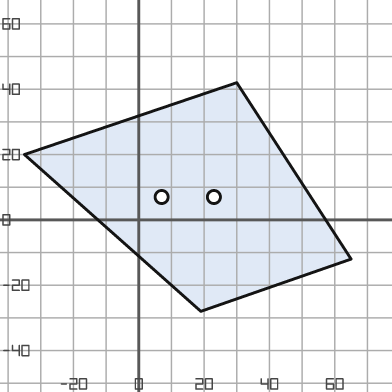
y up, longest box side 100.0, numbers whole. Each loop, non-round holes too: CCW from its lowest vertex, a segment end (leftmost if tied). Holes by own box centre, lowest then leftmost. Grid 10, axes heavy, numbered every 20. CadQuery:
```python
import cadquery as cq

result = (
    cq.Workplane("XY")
    .moveTo(19.0, -28.0)
    .lineTo(65.0, -12.0)
    .lineTo(30.0, 42.0)
    .lineTo(-35.0, 20.0)
    .close()
    .moveTo(7.0, 7.0)
    .circle(2.0)
    .moveTo(23.0, 7.0)
    .circle(2.0)
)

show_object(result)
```